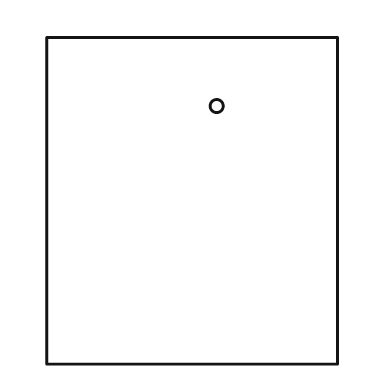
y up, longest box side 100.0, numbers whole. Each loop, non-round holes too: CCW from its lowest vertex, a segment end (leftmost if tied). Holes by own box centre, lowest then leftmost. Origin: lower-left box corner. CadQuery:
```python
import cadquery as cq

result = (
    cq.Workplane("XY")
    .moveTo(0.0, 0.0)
    .lineTo(89.0, 0.0)
    .lineTo(89.0, 100.0)
    .lineTo(0.0, 100.0)
    .close()
    .moveTo(52.0, 79.0)
    .circle(2.0)
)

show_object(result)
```